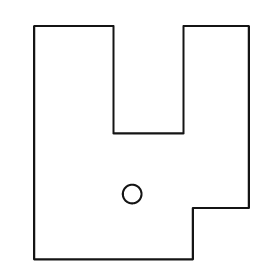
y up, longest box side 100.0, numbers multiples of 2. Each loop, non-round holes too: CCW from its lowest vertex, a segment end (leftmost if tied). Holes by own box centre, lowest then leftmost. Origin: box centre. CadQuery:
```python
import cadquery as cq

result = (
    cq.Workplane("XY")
    .moveTo(-46.0, -50.0)
    .lineTo(22.0, -50.0)
    .lineTo(22.0, -28.0)
    .lineTo(46.0, -28.0)
    .lineTo(46.0, 50.0)
    .lineTo(18.0, 50.0)
    .lineTo(18.0, 4.0)
    .lineTo(-12.0, 4.0)
    .lineTo(-12.0, 50.0)
    .lineTo(-46.0, 50.0)
    .close()
    .moveTo(-4.0, -22.0)
    .circle(4.0)
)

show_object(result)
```